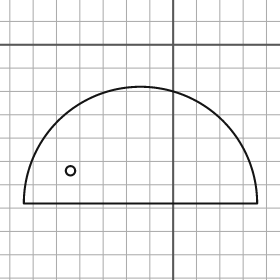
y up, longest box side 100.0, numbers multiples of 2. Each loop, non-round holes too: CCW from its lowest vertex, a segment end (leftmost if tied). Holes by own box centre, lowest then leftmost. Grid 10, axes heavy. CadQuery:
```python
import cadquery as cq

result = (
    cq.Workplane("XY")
    .moveTo(-64.0, -68.0)
    .lineTo(36.0, -68.0)
    .threePointArc((-14.0, -18.0), (-64.0, -68.0))
    .close()
    .moveTo(-44.0, -54.0)
    .circle(2.0)
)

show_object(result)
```